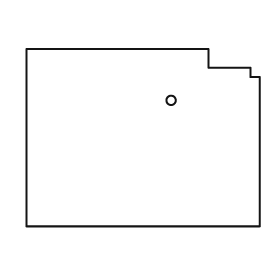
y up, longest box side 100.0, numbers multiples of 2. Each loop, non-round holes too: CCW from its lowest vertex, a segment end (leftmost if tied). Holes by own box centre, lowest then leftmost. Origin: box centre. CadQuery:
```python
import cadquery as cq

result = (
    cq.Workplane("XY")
    .moveTo(-50.0, -38.0)
    .lineTo(50.0, -38.0)
    .lineTo(50.0, 26.0)
    .lineTo(46.0, 26.0)
    .lineTo(46.0, 30.0)
    .lineTo(28.0, 30.0)
    .lineTo(28.0, 38.0)
    .lineTo(-50.0, 38.0)
    .close()
    .moveTo(12.0, 16.0)
    .circle(2.0)
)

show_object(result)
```